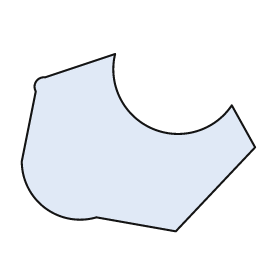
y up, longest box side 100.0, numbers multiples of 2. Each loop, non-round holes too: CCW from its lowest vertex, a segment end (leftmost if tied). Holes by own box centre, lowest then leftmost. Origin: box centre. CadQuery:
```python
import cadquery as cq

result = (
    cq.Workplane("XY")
    .moveTo(16.0, -38.0)
    .lineTo(50.0, -2.0)
    .lineTo(40.0, 16.0)
    .threePointArc((6.0, 6.0), (-10.0, 38.0))
    .lineTo(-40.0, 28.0)
    .threePointArc((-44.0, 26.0), (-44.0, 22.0))
    .lineTo(-50.0, -8.0)
    .threePointArc((-40.0, -28.0), (-18.0, -32.0))
    .close()
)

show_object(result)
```